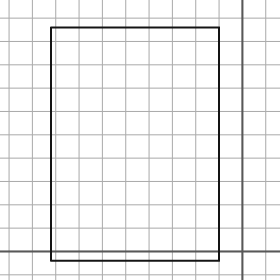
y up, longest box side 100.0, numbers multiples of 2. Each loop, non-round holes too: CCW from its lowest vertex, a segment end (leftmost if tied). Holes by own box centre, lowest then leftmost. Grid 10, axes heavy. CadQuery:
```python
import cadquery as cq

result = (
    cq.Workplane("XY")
    .moveTo(-82.0, -4.0)
    .lineTo(-10.0, -4.0)
    .lineTo(-10.0, 96.0)
    .lineTo(-82.0, 96.0)
    .close()
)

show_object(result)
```